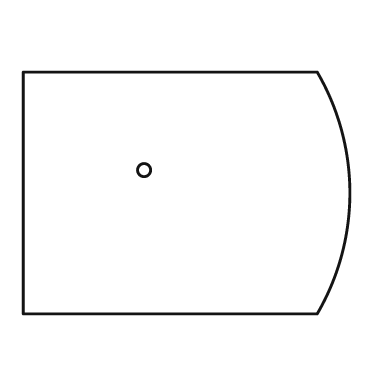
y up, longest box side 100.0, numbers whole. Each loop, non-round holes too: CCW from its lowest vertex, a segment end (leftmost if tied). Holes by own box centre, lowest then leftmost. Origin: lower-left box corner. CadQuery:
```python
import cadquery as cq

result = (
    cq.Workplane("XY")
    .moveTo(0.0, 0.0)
    .lineTo(90.0, 0.0)
    .threePointArc((100.0, 37.0), (90.0, 74.0))
    .lineTo(0.0, 74.0)
    .close()
    .moveTo(37.0, 44.0)
    .circle(2.0)
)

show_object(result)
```